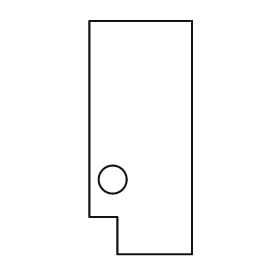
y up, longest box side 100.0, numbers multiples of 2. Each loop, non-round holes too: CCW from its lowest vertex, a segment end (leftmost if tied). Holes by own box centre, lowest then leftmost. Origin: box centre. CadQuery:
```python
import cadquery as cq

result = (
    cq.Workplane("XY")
    .moveTo(-10.0, -50.0)
    .lineTo(22.0, -50.0)
    .lineTo(22.0, 50.0)
    .lineTo(-22.0, 50.0)
    .lineTo(-22.0, -34.0)
    .lineTo(-10.0, -34.0)
    .close()
    .moveTo(-12.0, -18.0)
    .circle(6.0)
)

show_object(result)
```